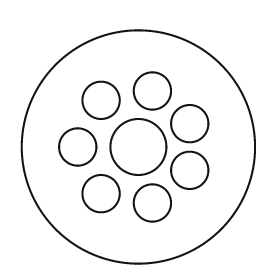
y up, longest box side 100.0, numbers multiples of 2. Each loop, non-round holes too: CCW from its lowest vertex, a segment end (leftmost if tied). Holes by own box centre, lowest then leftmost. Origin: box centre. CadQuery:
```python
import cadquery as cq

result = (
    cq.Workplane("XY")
    .moveTo(0.0, 0.0)
    .circle(50.0)
    .moveTo(6.0, -24.0)
    .circle(8.0)
    .moveTo(-16.0, -20.0)
    .circle(8.0)
    .moveTo(22.0, -10.0)
    .circle(8.0)
    .moveTo(-26.0, 0.0)
    .circle(8.0)
    .moveTo(0.0, 0.0)
    .circle(12.0)
    .moveTo(22.0, 10.0)
    .circle(8.0)
    .moveTo(-16.0, 20.0)
    .circle(8.0)
    .moveTo(6.0, 24.0)
    .circle(8.0)
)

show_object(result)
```